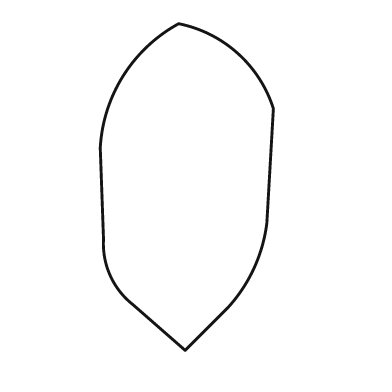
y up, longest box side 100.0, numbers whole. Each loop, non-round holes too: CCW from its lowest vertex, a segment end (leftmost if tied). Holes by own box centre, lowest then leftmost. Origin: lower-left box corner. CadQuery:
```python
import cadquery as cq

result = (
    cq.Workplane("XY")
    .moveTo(26.0, 0.0)
    .lineTo(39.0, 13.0)
    .threePointArc((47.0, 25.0), (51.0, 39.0))
    .lineTo(53.0, 74.0)
    .threePointArc((42.0, 91.0), (24.0, 100.0))
    .threePointArc((7.0, 84.0), (0.0, 62.0))
    .lineTo(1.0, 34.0)
    .threePointArc((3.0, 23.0), (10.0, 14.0))
    .close()
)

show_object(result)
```